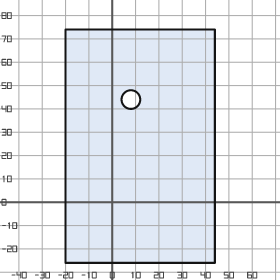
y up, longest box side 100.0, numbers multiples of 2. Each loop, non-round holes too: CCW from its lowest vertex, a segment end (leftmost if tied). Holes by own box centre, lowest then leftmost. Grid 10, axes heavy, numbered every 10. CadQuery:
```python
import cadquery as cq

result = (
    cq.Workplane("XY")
    .moveTo(-20.0, -26.0)
    .lineTo(44.0, -26.0)
    .lineTo(44.0, 74.0)
    .lineTo(-20.0, 74.0)
    .close()
    .moveTo(8.0, 44.0)
    .circle(4.0)
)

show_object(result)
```